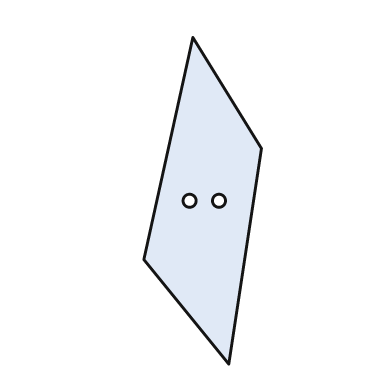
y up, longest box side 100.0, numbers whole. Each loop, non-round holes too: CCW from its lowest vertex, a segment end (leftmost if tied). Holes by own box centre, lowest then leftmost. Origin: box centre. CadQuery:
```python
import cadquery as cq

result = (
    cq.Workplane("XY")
    .moveTo(8.0, -50.0)
    .lineTo(18.0, 16.0)
    .lineTo(-3.0, 50.0)
    .lineTo(-18.0, -18.0)
    .close()
    .moveTo(-4.0, 0.0)
    .circle(2.0)
    .moveTo(5.0, 0.0)
    .circle(2.0)
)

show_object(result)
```